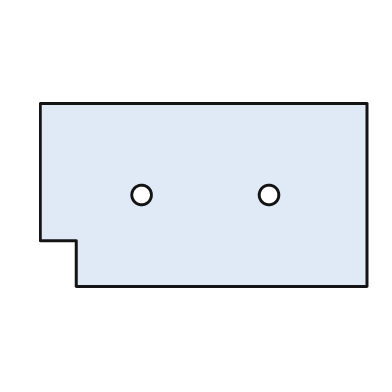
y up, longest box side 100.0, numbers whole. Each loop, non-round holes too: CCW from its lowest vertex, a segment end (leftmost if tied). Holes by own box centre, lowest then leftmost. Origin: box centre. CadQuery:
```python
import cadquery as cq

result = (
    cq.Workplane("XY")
    .moveTo(-39.0, -28.0)
    .lineTo(50.0, -28.0)
    .lineTo(50.0, 28.0)
    .lineTo(-50.0, 28.0)
    .lineTo(-50.0, -14.0)
    .lineTo(-39.0, -14.0)
    .close()
    .moveTo(-19.0, 0.0)
    .circle(3.0)
    .moveTo(20.0, 0.0)
    .circle(3.0)
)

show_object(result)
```